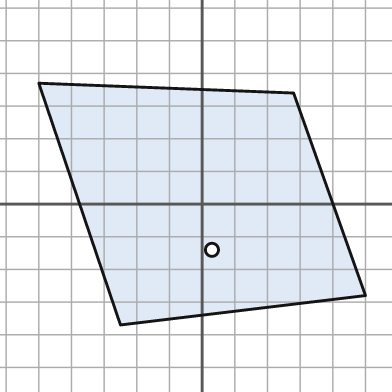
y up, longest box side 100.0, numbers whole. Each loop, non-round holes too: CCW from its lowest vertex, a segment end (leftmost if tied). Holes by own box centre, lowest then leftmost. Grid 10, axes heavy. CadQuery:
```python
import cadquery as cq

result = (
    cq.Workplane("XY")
    .moveTo(-25.0, -37.0)
    .lineTo(50.0, -28.0)
    .lineTo(28.0, 34.0)
    .lineTo(-50.0, 37.0)
    .close()
    .moveTo(3.0, -14.0)
    .circle(2.0)
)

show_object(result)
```